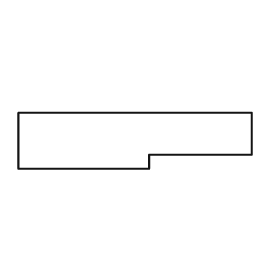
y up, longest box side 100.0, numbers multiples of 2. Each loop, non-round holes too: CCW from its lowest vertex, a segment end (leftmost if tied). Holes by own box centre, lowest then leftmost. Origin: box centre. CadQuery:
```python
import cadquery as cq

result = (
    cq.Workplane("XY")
    .moveTo(-50.0, -12.0)
    .lineTo(6.0, -12.0)
    .lineTo(6.0, -6.0)
    .lineTo(50.0, -6.0)
    .lineTo(50.0, 12.0)
    .lineTo(-50.0, 12.0)
    .close()
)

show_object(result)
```